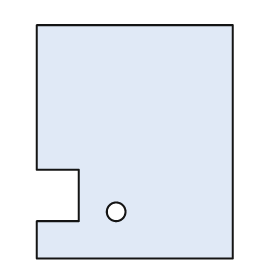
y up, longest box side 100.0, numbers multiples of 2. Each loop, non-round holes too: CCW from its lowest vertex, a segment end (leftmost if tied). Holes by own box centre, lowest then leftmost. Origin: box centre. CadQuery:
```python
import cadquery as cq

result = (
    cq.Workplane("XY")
    .moveTo(-42.0, -50.0)
    .lineTo(42.0, -50.0)
    .lineTo(42.0, 50.0)
    .lineTo(-42.0, 50.0)
    .lineTo(-42.0, -12.0)
    .lineTo(-24.0, -12.0)
    .lineTo(-24.0, -34.0)
    .lineTo(-42.0, -34.0)
    .close()
    .moveTo(-8.0, -30.0)
    .circle(4.0)
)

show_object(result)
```